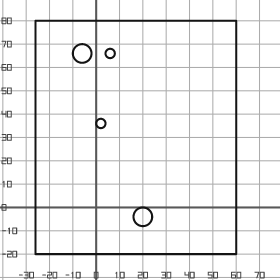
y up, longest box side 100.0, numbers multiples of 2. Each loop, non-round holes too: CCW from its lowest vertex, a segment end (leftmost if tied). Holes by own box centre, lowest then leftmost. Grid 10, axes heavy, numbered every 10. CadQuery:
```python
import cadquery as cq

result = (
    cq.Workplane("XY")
    .moveTo(-26.0, -20.0)
    .lineTo(60.0, -20.0)
    .lineTo(60.0, 80.0)
    .lineTo(-26.0, 80.0)
    .close()
    .moveTo(20.0, -4.0)
    .circle(4.0)
    .moveTo(2.0, 36.0)
    .circle(2.0)
    .moveTo(-6.0, 66.0)
    .circle(4.0)
    .moveTo(6.0, 66.0)
    .circle(2.0)
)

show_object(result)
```